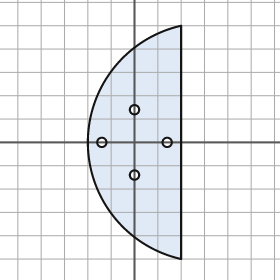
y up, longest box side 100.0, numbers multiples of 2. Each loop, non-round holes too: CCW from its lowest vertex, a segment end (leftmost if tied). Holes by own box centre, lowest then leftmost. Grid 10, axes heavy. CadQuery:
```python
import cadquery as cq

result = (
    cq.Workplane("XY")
    .moveTo(20.0, -50.0)
    .lineTo(20.0, 50.0)
    .threePointArc((-20.0, 0.0), (20.0, -50.0))
    .close()
    .moveTo(0.0, -14.0)
    .circle(2.0)
    .moveTo(-14.0, 0.0)
    .circle(2.0)
    .moveTo(14.0, 0.0)
    .circle(2.0)
    .moveTo(0.0, 14.0)
    .circle(2.0)
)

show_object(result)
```